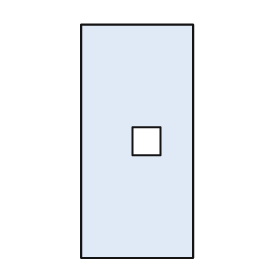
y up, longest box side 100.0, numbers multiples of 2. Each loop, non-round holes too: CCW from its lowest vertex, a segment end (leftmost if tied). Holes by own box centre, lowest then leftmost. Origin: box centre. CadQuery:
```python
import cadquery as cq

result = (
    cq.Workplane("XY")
    .moveTo(-24.0, -50.0)
    .lineTo(24.0, -50.0)
    .lineTo(24.0, 50.0)
    .lineTo(-24.0, 50.0)
    .close()
    .moveTo(-2.0, -6.0)
    .lineTo(10.0, -6.0)
    .lineTo(10.0, 6.0)
    .lineTo(-2.0, 6.0)
    .close()
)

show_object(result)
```